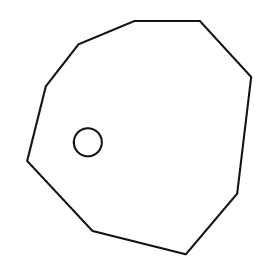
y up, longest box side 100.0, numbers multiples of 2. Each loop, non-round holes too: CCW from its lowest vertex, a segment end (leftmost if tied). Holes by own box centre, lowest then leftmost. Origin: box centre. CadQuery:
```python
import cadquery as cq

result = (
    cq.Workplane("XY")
    .moveTo(20.0, -50.0)
    .lineTo(42.0, -24.0)
    .lineTo(48.0, 26.0)
    .lineTo(26.0, 50.0)
    .lineTo(-2.0, 50.0)
    .lineTo(-26.0, 40.0)
    .lineTo(-40.0, 22.0)
    .lineTo(-48.0, -10.0)
    .lineTo(-20.0, -40.0)
    .close()
    .moveTo(-22.0, -2.0)
    .circle(6.0)
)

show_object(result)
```